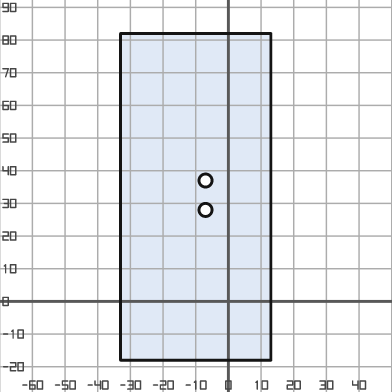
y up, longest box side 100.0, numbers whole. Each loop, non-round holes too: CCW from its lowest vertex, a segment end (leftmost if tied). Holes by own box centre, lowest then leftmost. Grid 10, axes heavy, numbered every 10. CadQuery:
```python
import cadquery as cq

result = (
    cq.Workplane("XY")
    .moveTo(-33.0, -18.0)
    .lineTo(13.0, -18.0)
    .lineTo(13.0, 82.0)
    .lineTo(-33.0, 82.0)
    .close()
    .moveTo(-7.0, 28.0)
    .circle(2.0)
    .moveTo(-7.0, 37.0)
    .circle(2.0)
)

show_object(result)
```